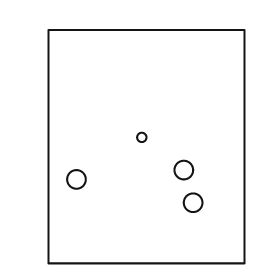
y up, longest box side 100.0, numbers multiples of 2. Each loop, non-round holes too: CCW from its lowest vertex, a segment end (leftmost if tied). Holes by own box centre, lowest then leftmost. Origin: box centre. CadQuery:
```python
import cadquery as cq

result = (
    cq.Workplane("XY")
    .moveTo(-42.0, -50.0)
    .lineTo(42.0, -50.0)
    .lineTo(42.0, 50.0)
    .lineTo(-42.0, 50.0)
    .close()
    .moveTo(20.0, -24.0)
    .circle(4.0)
    .moveTo(-30.0, -14.0)
    .circle(4.0)
    .moveTo(16.0, -10.0)
    .circle(4.0)
    .moveTo(-2.0, 4.0)
    .circle(2.0)
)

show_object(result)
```